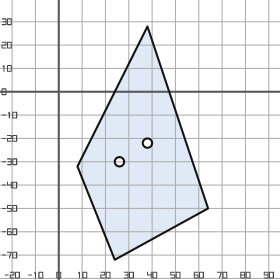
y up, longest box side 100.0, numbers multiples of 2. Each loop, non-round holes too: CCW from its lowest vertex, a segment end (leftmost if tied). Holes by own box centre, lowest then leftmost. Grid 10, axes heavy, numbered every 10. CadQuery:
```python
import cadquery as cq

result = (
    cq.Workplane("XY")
    .moveTo(24.0, -72.0)
    .lineTo(64.0, -50.0)
    .lineTo(38.0, 28.0)
    .lineTo(8.0, -32.0)
    .close()
    .moveTo(26.0, -30.0)
    .circle(2.0)
    .moveTo(38.0, -22.0)
    .circle(2.0)
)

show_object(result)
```